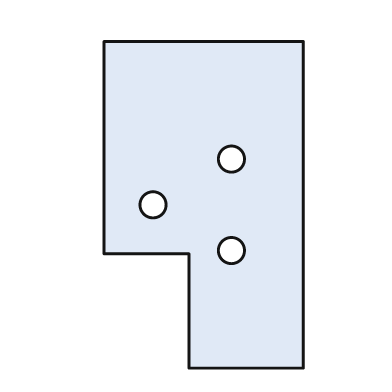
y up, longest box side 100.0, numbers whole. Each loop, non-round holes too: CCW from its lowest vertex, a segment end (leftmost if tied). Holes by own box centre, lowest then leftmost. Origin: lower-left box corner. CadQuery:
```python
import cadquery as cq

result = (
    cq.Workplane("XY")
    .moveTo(26.0, 0.0)
    .lineTo(61.0, 0.0)
    .lineTo(61.0, 100.0)
    .lineTo(0.0, 100.0)
    .lineTo(0.0, 35.0)
    .lineTo(26.0, 35.0)
    .close()
    .moveTo(39.0, 36.0)
    .circle(4.0)
    .moveTo(15.0, 50.0)
    .circle(4.0)
    .moveTo(39.0, 64.0)
    .circle(4.0)
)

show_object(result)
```